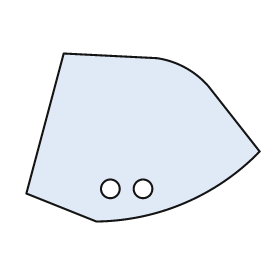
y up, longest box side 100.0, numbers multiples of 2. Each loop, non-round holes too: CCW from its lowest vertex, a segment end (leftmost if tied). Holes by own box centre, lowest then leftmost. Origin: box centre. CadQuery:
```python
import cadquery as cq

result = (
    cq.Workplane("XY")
    .moveTo(-20.0, -36.0)
    .threePointArc((18.0, -28.0), (50.0, -6.0))
    .lineTo(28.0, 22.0)
    .threePointArc((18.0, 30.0), (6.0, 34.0))
    .lineTo(-34.0, 36.0)
    .lineTo(-50.0, -24.0)
    .close()
    .moveTo(-14.0, -22.0)
    .circle(4.0)
    .moveTo(0.0, -22.0)
    .circle(4.0)
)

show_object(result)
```